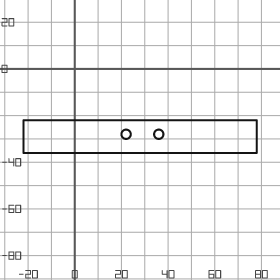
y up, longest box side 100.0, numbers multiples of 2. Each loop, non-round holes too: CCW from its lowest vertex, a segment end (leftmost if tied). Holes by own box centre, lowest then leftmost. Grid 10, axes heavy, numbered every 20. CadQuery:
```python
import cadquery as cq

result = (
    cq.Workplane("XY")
    .moveTo(-22.0, -36.0)
    .lineTo(78.0, -36.0)
    .lineTo(78.0, -22.0)
    .lineTo(-22.0, -22.0)
    .close()
    .moveTo(22.0, -28.0)
    .circle(2.0)
    .moveTo(36.0, -28.0)
    .circle(2.0)
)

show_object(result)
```